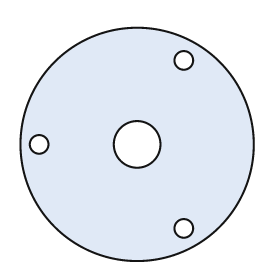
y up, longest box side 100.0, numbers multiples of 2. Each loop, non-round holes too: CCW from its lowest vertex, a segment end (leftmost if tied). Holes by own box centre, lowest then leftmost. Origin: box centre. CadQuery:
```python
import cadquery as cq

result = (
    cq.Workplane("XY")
    .moveTo(0.0, 0.0)
    .circle(50.0)
    .moveTo(20.0, -36.0)
    .circle(4.0)
    .moveTo(-42.0, 0.0)
    .circle(4.0)
    .moveTo(0.0, 0.0)
    .circle(10.0)
    .moveTo(20.0, 36.0)
    .circle(4.0)
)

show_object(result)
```